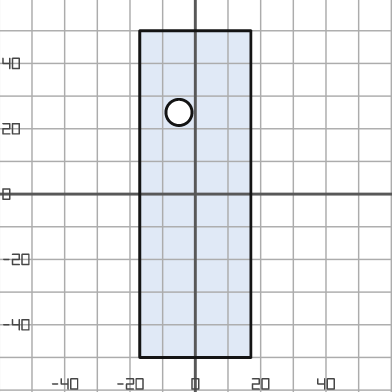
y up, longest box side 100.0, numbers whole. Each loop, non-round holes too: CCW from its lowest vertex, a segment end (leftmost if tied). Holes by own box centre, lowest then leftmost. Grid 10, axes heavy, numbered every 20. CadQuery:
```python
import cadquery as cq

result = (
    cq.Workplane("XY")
    .moveTo(-17.0, -50.0)
    .lineTo(17.0, -50.0)
    .lineTo(17.0, 50.0)
    .lineTo(-17.0, 50.0)
    .close()
    .moveTo(-5.0, 25.0)
    .circle(4.0)
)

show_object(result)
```